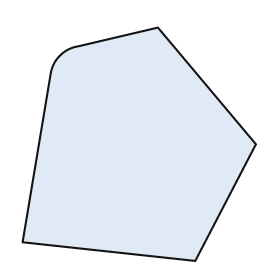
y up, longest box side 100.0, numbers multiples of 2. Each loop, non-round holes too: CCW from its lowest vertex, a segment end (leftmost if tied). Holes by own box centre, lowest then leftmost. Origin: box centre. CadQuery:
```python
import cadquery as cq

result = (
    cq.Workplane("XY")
    .moveTo(24.0, -50.0)
    .lineTo(50.0, 0.0)
    .lineTo(8.0, 50.0)
    .lineTo(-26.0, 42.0)
    .threePointArc((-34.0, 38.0), (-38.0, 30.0))
    .lineTo(-50.0, -42.0)
    .close()
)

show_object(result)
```